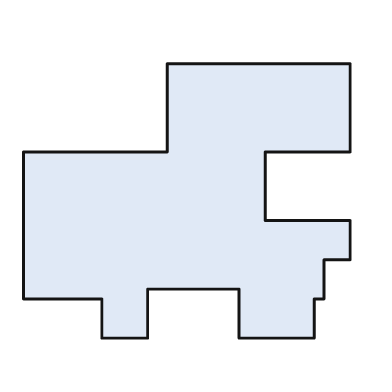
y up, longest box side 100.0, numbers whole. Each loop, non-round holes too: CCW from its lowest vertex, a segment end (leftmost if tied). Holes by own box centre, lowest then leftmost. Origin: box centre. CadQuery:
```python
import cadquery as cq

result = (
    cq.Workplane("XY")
    .moveTo(-26.0, -42.0)
    .lineTo(-12.0, -42.0)
    .lineTo(-12.0, -27.0)
    .lineTo(16.0, -27.0)
    .lineTo(16.0, -42.0)
    .lineTo(39.0, -42.0)
    .lineTo(39.0, -30.0)
    .lineTo(42.0, -30.0)
    .lineTo(42.0, -18.0)
    .lineTo(50.0, -18.0)
    .lineTo(50.0, -6.0)
    .lineTo(24.0, -6.0)
    .lineTo(24.0, 15.0)
    .lineTo(50.0, 15.0)
    .lineTo(50.0, 42.0)
    .lineTo(-6.0, 42.0)
    .lineTo(-6.0, 15.0)
    .lineTo(-50.0, 15.0)
    .lineTo(-50.0, -30.0)
    .lineTo(-26.0, -30.0)
    .close()
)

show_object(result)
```